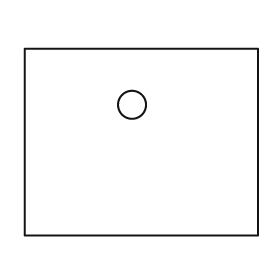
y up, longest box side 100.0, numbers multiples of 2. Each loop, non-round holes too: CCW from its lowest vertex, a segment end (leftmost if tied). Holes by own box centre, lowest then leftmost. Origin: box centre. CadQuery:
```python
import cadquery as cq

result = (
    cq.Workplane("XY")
    .moveTo(-50.0, -40.0)
    .lineTo(50.0, -40.0)
    .lineTo(50.0, 40.0)
    .lineTo(-50.0, 40.0)
    .close()
    .moveTo(-4.0, 16.0)
    .circle(6.0)
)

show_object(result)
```